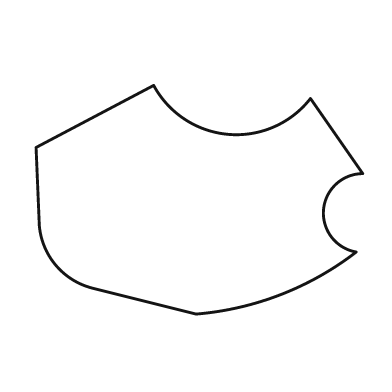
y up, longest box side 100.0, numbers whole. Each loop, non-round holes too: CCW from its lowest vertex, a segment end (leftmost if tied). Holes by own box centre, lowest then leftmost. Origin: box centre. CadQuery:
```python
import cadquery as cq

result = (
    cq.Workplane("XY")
    .moveTo(-1.0, -35.0)
    .threePointArc((25.0, -29.0), (48.0, -16.0))
    .threePointArc((38.0, -3.0), (50.0, 8.0))
    .lineTo(34.0, 31.0)
    .threePointArc((9.0, 20.0), (-14.0, 35.0))
    .lineTo(-50.0, 16.0)
    .lineTo(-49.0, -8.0)
    .threePointArc((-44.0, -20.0), (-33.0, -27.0))
    .close()
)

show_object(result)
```